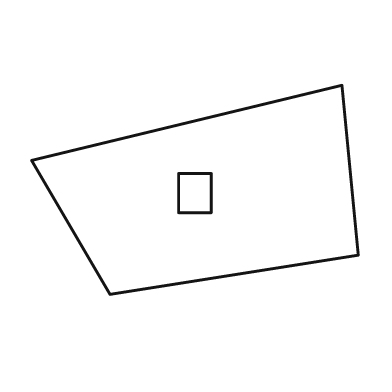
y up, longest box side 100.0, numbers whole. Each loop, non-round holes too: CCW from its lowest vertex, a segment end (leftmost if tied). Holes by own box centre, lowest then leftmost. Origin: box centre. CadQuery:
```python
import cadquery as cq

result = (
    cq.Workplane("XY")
    .moveTo(-26.0, -32.0)
    .lineTo(50.0, -20.0)
    .lineTo(45.0, 32.0)
    .lineTo(-50.0, 9.0)
    .close()
    .moveTo(-5.0, -7.0)
    .lineTo(5.0, -7.0)
    .lineTo(5.0, 5.0)
    .lineTo(-5.0, 5.0)
    .close()
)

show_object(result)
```